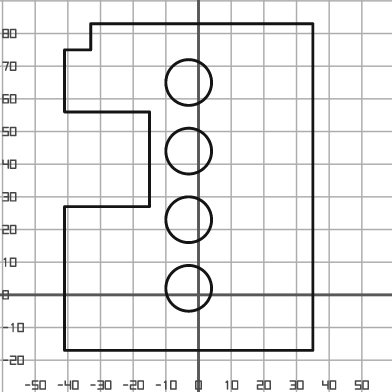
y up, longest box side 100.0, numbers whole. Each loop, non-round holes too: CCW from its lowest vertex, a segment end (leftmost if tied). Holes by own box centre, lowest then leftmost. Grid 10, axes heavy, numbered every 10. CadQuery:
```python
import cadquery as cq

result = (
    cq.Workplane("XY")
    .moveTo(-41.0, -17.0)
    .lineTo(35.0, -17.0)
    .lineTo(35.0, 83.0)
    .lineTo(-33.0, 83.0)
    .lineTo(-33.0, 75.0)
    .lineTo(-41.0, 75.0)
    .lineTo(-41.0, 56.0)
    .lineTo(-15.0, 56.0)
    .lineTo(-15.0, 27.0)
    .lineTo(-41.0, 27.0)
    .close()
    .moveTo(-3.0, 2.0)
    .circle(7.0)
    .moveTo(-3.0, 23.0)
    .circle(7.0)
    .moveTo(-3.0, 44.0)
    .circle(7.0)
    .moveTo(-3.0, 65.0)
    .circle(7.0)
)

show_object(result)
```